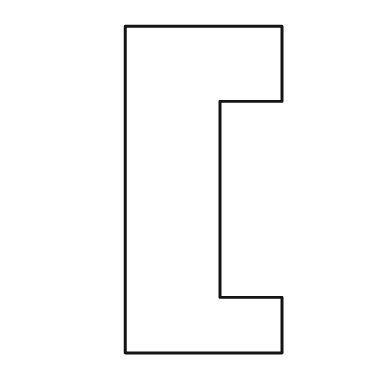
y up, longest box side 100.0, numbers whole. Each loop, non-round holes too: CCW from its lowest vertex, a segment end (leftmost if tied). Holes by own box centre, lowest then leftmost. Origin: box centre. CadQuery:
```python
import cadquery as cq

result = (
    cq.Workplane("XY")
    .moveTo(-24.0, -50.0)
    .lineTo(24.0, -50.0)
    .lineTo(24.0, -33.0)
    .lineTo(5.0, -33.0)
    .lineTo(5.0, 27.0)
    .lineTo(24.0, 27.0)
    .lineTo(24.0, 50.0)
    .lineTo(-24.0, 50.0)
    .close()
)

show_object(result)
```